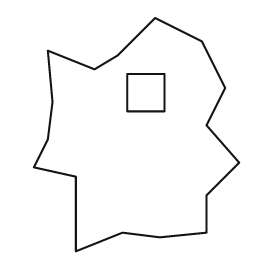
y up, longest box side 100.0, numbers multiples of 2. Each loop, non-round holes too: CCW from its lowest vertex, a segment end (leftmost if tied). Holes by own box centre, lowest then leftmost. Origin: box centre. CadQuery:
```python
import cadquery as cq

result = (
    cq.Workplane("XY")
    .moveTo(-26.0, -50.0)
    .lineTo(-6.0, -42.0)
    .lineTo(10.0, -44.0)
    .lineTo(30.0, -42.0)
    .lineTo(30.0, -26.0)
    .lineTo(44.0, -12.0)
    .lineTo(30.0, 4.0)
    .lineTo(38.0, 20.0)
    .lineTo(28.0, 40.0)
    .lineTo(8.0, 50.0)
    .lineTo(-8.0, 34.0)
    .lineTo(-18.0, 28.0)
    .lineTo(-38.0, 36.0)
    .lineTo(-36.0, 14.0)
    .lineTo(-38.0, -2.0)
    .lineTo(-44.0, -14.0)
    .lineTo(-26.0, -18.0)
    .close()
    .moveTo(-4.0, 10.0)
    .lineTo(12.0, 10.0)
    .lineTo(12.0, 26.0)
    .lineTo(-4.0, 26.0)
    .close()
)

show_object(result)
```